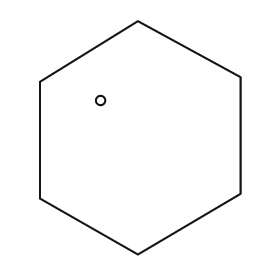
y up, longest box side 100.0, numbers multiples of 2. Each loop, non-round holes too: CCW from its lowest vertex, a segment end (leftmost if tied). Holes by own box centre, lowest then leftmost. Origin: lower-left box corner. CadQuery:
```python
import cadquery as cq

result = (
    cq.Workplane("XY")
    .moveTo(42.0, 0.0)
    .lineTo(86.0, 26.0)
    .lineTo(86.0, 76.0)
    .lineTo(42.0, 100.0)
    .lineTo(0.0, 74.0)
    .lineTo(0.0, 24.0)
    .close()
    .moveTo(26.0, 66.0)
    .circle(2.0)
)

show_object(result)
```